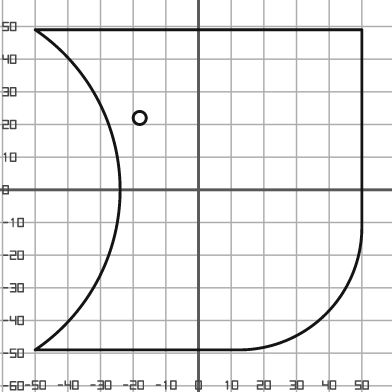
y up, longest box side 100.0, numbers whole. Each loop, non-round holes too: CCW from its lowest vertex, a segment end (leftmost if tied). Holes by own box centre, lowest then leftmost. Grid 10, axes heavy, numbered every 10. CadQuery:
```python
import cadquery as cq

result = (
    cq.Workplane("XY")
    .moveTo(-50.0, -49.0)
    .lineTo(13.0, -49.0)
    .threePointArc((39.0, -38.0), (50.0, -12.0))
    .lineTo(50.0, 49.0)
    .lineTo(-50.0, 49.0)
    .threePointArc((-24.0, 0.0), (-50.0, -49.0))
    .close()
    .moveTo(-18.0, 22.0)
    .circle(2.0)
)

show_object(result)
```